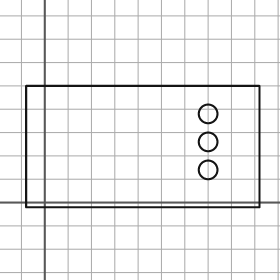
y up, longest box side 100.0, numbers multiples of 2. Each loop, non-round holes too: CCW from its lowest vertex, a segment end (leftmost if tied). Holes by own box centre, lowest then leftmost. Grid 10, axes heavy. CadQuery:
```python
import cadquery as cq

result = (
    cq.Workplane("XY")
    .moveTo(-8.0, -2.0)
    .lineTo(92.0, -2.0)
    .lineTo(92.0, 50.0)
    .lineTo(-8.0, 50.0)
    .close()
    .moveTo(70.0, 14.0)
    .circle(4.0)
    .moveTo(70.0, 26.0)
    .circle(4.0)
    .moveTo(70.0, 38.0)
    .circle(4.0)
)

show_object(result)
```